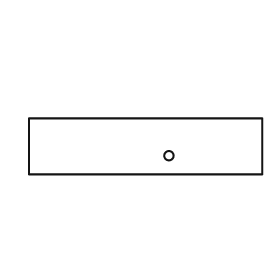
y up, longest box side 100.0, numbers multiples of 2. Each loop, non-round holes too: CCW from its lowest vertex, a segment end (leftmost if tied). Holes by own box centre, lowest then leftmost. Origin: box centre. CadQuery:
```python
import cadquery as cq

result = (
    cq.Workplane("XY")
    .moveTo(-50.0, -12.0)
    .lineTo(50.0, -12.0)
    .lineTo(50.0, 12.0)
    .lineTo(-50.0, 12.0)
    .close()
    .moveTo(10.0, -4.0)
    .circle(2.0)
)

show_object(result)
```